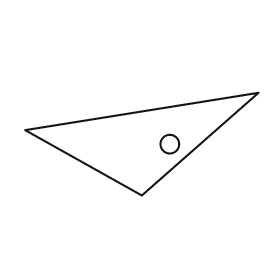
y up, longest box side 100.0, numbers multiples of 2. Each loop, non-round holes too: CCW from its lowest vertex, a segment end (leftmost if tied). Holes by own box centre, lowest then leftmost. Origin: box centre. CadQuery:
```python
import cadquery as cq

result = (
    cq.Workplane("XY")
    .moveTo(0.0, -22.0)
    .lineTo(50.0, 22.0)
    .lineTo(-50.0, 6.0)
    .close()
    .moveTo(12.0, 0.0)
    .circle(4.0)
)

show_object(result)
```